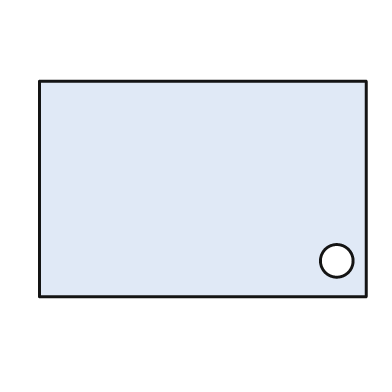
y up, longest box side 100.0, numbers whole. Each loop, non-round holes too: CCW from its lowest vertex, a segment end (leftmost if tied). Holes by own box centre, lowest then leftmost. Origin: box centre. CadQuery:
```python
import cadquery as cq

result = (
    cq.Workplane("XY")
    .moveTo(-50.0, -33.0)
    .lineTo(50.0, -33.0)
    .lineTo(50.0, 33.0)
    .lineTo(-50.0, 33.0)
    .close()
    .moveTo(41.0, -22.0)
    .circle(5.0)
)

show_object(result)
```